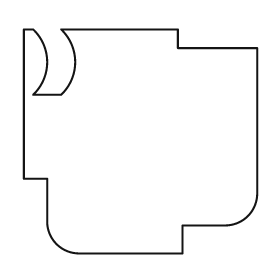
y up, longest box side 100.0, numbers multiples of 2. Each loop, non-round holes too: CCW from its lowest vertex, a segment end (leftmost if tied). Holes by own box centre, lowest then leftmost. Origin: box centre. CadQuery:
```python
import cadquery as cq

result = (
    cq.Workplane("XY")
    .moveTo(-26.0, -48.0)
    .lineTo(18.0, -48.0)
    .lineTo(18.0, -36.0)
    .lineTo(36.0, -36.0)
    .threePointArc((46.0, -32.0), (50.0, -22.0))
    .lineTo(50.0, 40.0)
    .lineTo(16.0, 40.0)
    .lineTo(16.0, 48.0)
    .lineTo(-34.0, 48.0)
    .threePointArc((-28.0, 34.0), (-34.0, 20.0))
    .lineTo(-46.0, 20.0)
    .threePointArc((-40.0, 34.0), (-46.0, 48.0))
    .lineTo(-50.0, 48.0)
    .lineTo(-50.0, -16.0)
    .lineTo(-40.0, -16.0)
    .lineTo(-40.0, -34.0)
    .threePointArc((-36.0, -44.0), (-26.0, -48.0))
    .close()
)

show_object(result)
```